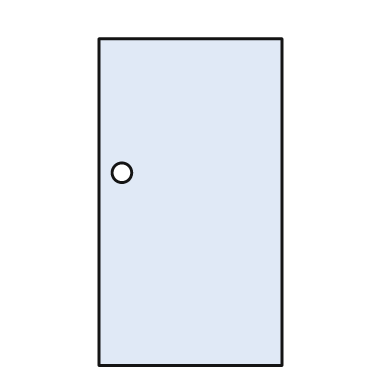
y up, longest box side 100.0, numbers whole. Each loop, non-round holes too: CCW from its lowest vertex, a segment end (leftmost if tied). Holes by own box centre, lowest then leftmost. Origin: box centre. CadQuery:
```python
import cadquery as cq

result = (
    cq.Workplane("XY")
    .moveTo(-28.0, -50.0)
    .lineTo(28.0, -50.0)
    .lineTo(28.0, 50.0)
    .lineTo(-28.0, 50.0)
    .close()
    .moveTo(-21.0, 9.0)
    .circle(3.0)
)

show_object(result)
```